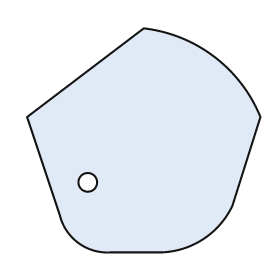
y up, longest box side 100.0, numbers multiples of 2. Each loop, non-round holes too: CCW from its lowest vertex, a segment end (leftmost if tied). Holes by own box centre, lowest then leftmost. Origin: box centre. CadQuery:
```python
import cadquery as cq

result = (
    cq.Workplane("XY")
    .moveTo(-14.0, -48.0)
    .lineTo(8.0, -48.0)
    .threePointArc((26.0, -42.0), (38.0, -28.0))
    .lineTo(50.0, 10.0)
    .threePointArc((30.0, 36.0), (0.0, 48.0))
    .lineTo(-50.0, 10.0)
    .lineTo(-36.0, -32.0)
    .threePointArc((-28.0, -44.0), (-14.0, -48.0))
    .close()
    .moveTo(-24.0, -18.0)
    .circle(4.0)
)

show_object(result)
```